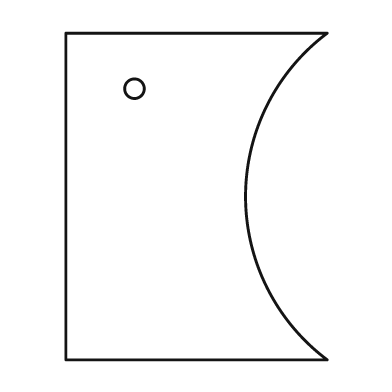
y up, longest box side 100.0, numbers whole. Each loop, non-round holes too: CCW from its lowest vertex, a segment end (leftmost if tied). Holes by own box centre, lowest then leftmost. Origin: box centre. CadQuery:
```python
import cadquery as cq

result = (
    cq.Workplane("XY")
    .moveTo(-40.0, -50.0)
    .lineTo(40.0, -50.0)
    .threePointArc((15.0, 0.0), (40.0, 50.0))
    .lineTo(-40.0, 50.0)
    .close()
    .moveTo(-19.0, 33.0)
    .circle(3.0)
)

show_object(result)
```